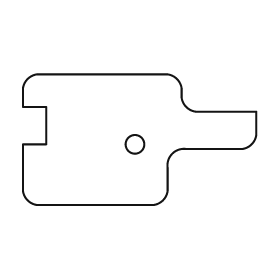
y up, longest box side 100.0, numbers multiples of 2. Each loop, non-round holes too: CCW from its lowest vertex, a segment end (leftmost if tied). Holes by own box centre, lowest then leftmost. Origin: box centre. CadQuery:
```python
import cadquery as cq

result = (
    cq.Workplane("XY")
    .moveTo(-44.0, -28.0)
    .lineTo(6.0, -28.0)
    .threePointArc((10.0, -26.0), (12.0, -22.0))
    .lineTo(12.0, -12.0)
    .threePointArc((14.0, -6.0), (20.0, -4.0))
    .lineTo(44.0, -4.0)
    .threePointArc((48.0, -2.0), (50.0, 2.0))
    .lineTo(50.0, 12.0)
    .lineTo(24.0, 12.0)
    .threePointArc((20.0, 14.0), (18.0, 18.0))
    .lineTo(18.0, 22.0)
    .threePointArc((16.0, 26.0), (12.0, 28.0))
    .lineTo(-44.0, 28.0)
    .threePointArc((-48.0, 26.0), (-50.0, 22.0))
    .lineTo(-50.0, 14.0)
    .lineTo(-40.0, 14.0)
    .lineTo(-40.0, -2.0)
    .lineTo(-50.0, -2.0)
    .lineTo(-50.0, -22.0)
    .threePointArc((-48.0, -26.0), (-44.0, -28.0))
    .close()
    .moveTo(-2.0, -2.0)
    .circle(4.0)
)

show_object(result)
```